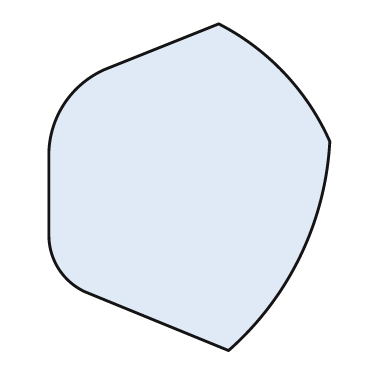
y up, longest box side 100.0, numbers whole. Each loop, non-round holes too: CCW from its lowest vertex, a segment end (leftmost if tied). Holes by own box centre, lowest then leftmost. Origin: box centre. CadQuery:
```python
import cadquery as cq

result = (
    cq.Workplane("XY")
    .moveTo(12.0, -50.0)
    .threePointArc((34.0, -21.0), (43.0, 14.0))
    .threePointArc((29.0, 35.0), (9.0, 50.0))
    .lineTo(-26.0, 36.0)
    .threePointArc((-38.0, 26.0), (-43.0, 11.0))
    .lineTo(-43.0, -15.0)
    .threePointArc((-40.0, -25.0), (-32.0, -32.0))
    .close()
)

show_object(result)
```